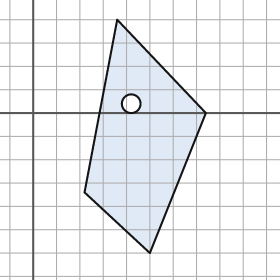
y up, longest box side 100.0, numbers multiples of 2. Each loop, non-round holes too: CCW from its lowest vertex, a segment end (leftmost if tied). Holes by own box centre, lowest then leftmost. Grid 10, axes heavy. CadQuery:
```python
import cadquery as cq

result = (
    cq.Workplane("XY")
    .moveTo(50.0, -60.0)
    .lineTo(74.0, 0.0)
    .lineTo(36.0, 40.0)
    .lineTo(22.0, -34.0)
    .close()
    .moveTo(42.0, 4.0)
    .circle(4.0)
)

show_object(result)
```